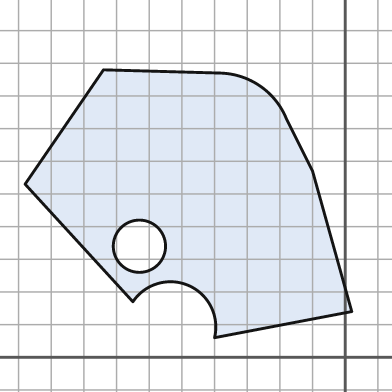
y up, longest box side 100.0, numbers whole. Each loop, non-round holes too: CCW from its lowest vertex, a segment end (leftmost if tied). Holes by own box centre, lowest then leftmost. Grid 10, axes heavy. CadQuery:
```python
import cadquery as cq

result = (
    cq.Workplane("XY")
    .moveTo(-40.0, 6.0)
    .lineTo(2.0, 14.0)
    .lineTo(-10.0, 57.0)
    .lineTo(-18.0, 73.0)
    .threePointArc((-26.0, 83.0), (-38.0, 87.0))
    .lineTo(-74.0, 88.0)
    .lineTo(-98.0, 53.0)
    .lineTo(-65.0, 17.0)
    .threePointArc((-48.0, 22.0), (-40.0, 6.0))
    .close()
    .moveTo(-63.0, 34.0)
    .circle(8.0)
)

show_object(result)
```